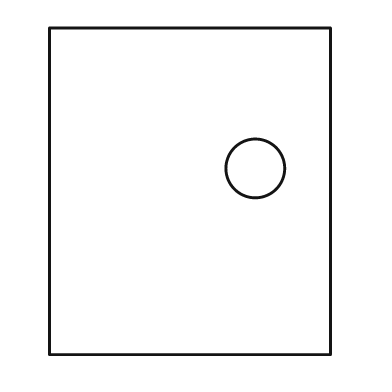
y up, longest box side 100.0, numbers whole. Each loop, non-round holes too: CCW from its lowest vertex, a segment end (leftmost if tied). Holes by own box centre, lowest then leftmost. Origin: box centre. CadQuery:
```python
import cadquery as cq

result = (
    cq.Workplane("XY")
    .moveTo(-43.0, -50.0)
    .lineTo(43.0, -50.0)
    .lineTo(43.0, 50.0)
    .lineTo(-43.0, 50.0)
    .close()
    .moveTo(20.0, 7.0)
    .circle(9.0)
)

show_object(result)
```